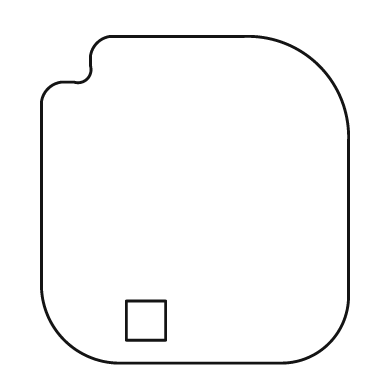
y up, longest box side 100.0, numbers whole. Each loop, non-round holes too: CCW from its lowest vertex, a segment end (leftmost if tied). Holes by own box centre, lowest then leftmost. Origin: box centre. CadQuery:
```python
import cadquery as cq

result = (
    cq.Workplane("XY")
    .moveTo(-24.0, -50.0)
    .lineTo(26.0, -50.0)
    .threePointArc((41.0, -44.0), (47.0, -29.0))
    .lineTo(47.0, 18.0)
    .threePointArc((38.0, 41.0), (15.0, 50.0))
    .lineTo(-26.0, 50.0)
    .threePointArc((-30.0, 48.0), (-32.0, 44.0))
    .lineTo(-32.0, 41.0)
    .threePointArc((-33.0, 37.0), (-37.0, 36.0))
    .lineTo(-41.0, 36.0)
    .threePointArc((-45.0, 34.0), (-47.0, 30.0))
    .lineTo(-47.0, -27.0)
    .threePointArc((-40.0, -43.0), (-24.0, -50.0))
    .close()
    .moveTo(-21.0, -43.0)
    .lineTo(-9.0, -43.0)
    .lineTo(-9.0, -31.0)
    .lineTo(-21.0, -31.0)
    .close()
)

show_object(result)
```